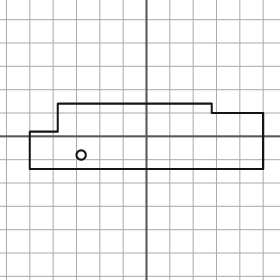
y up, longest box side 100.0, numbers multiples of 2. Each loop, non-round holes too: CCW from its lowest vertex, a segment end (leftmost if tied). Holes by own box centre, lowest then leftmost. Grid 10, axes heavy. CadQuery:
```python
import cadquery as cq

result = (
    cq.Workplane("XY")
    .moveTo(-50.0, -14.0)
    .lineTo(50.0, -14.0)
    .lineTo(50.0, 10.0)
    .lineTo(28.0, 10.0)
    .lineTo(28.0, 14.0)
    .lineTo(-38.0, 14.0)
    .lineTo(-38.0, 2.0)
    .lineTo(-50.0, 2.0)
    .close()
    .moveTo(-28.0, -8.0)
    .circle(2.0)
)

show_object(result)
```